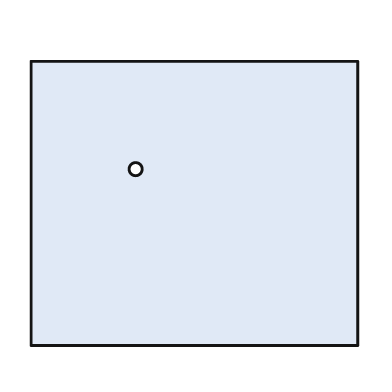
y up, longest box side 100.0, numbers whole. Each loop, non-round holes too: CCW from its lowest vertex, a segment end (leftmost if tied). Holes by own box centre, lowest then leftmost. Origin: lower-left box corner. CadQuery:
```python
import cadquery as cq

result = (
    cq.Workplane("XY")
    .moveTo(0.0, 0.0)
    .lineTo(100.0, 0.0)
    .lineTo(100.0, 87.0)
    .lineTo(0.0, 87.0)
    .close()
    .moveTo(32.0, 54.0)
    .circle(2.0)
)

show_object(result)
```